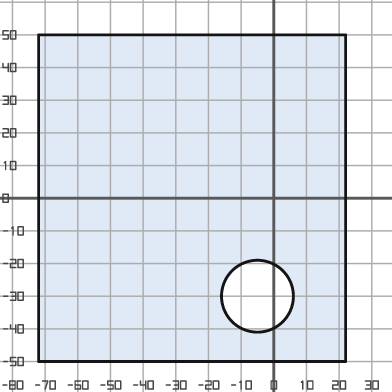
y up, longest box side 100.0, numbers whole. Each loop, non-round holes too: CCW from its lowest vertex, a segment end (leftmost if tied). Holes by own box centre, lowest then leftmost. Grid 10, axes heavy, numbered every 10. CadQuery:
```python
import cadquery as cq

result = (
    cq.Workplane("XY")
    .moveTo(-72.0, -50.0)
    .lineTo(22.0, -50.0)
    .lineTo(22.0, 50.0)
    .lineTo(-72.0, 50.0)
    .close()
    .moveTo(-5.0, -30.0)
    .circle(11.0)
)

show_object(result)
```